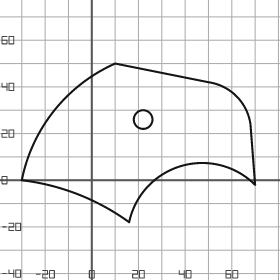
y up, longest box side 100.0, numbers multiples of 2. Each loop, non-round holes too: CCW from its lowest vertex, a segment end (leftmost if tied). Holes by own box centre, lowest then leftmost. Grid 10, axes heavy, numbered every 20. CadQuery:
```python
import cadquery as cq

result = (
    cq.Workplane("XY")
    .moveTo(16.0, -18.0)
    .threePointArc((38.0, 6.0), (70.0, -2.0))
    .lineTo(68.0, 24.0)
    .threePointArc((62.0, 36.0), (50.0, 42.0))
    .lineTo(10.0, 50.0)
    .threePointArc((-16.0, 30.0), (-30.0, 0.0))
    .threePointArc((-6.0, -6.0), (16.0, -18.0))
    .close()
    .moveTo(22.0, 26.0)
    .circle(4.0)
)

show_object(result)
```